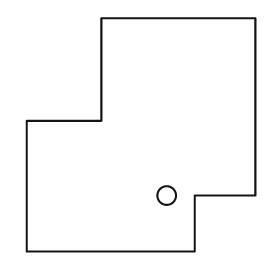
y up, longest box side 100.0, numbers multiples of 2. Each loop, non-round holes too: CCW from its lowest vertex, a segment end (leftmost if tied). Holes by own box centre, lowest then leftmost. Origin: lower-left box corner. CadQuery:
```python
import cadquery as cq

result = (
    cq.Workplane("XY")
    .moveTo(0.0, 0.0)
    .lineTo(72.0, 0.0)
    .lineTo(72.0, 24.0)
    .lineTo(98.0, 24.0)
    .lineTo(98.0, 100.0)
    .lineTo(32.0, 100.0)
    .lineTo(32.0, 56.0)
    .lineTo(0.0, 56.0)
    .close()
    .moveTo(60.0, 24.0)
    .circle(4.0)
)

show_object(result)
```